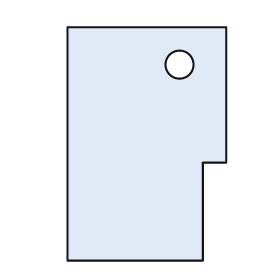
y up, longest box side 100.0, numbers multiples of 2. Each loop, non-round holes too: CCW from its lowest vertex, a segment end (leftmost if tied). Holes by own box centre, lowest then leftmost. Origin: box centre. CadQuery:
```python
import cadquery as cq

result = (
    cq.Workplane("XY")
    .moveTo(-34.0, -50.0)
    .lineTo(24.0, -50.0)
    .lineTo(24.0, -8.0)
    .lineTo(34.0, -8.0)
    .lineTo(34.0, 50.0)
    .lineTo(-34.0, 50.0)
    .close()
    .moveTo(14.0, 34.0)
    .circle(6.0)
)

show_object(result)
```